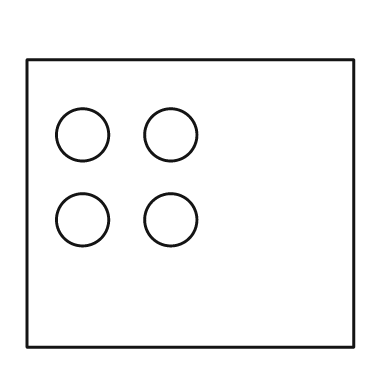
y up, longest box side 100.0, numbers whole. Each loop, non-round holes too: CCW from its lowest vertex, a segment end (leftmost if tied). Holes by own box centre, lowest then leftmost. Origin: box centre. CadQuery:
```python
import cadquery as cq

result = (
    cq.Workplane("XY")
    .moveTo(-50.0, -44.0)
    .lineTo(50.0, -44.0)
    .lineTo(50.0, 44.0)
    .lineTo(-50.0, 44.0)
    .close()
    .moveTo(-33.0, -5.0)
    .circle(8.0)
    .moveTo(-6.0, -5.0)
    .circle(8.0)
    .moveTo(-33.0, 21.0)
    .circle(8.0)
    .moveTo(-6.0, 21.0)
    .circle(8.0)
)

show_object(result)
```